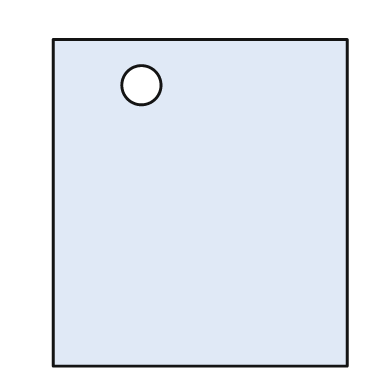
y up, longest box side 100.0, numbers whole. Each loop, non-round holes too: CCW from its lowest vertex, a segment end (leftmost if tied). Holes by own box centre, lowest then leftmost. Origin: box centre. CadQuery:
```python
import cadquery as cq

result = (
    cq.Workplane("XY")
    .moveTo(-45.0, -50.0)
    .lineTo(45.0, -50.0)
    .lineTo(45.0, 50.0)
    .lineTo(-45.0, 50.0)
    .close()
    .moveTo(-18.0, 36.0)
    .circle(6.0)
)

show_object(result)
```